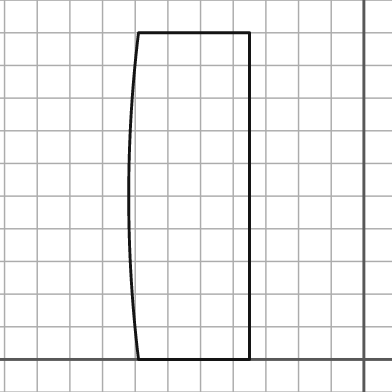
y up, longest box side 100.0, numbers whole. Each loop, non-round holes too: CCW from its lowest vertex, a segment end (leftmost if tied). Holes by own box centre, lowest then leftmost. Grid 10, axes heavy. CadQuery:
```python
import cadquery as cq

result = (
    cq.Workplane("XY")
    .moveTo(-69.0, 0.0)
    .lineTo(-35.0, 0.0)
    .lineTo(-35.0, 100.0)
    .lineTo(-69.0, 100.0)
    .threePointArc((-72.0, 50.0), (-69.0, 0.0))
    .close()
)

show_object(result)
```